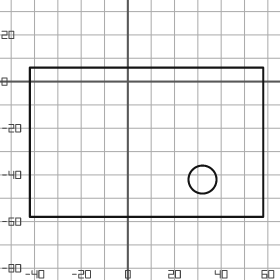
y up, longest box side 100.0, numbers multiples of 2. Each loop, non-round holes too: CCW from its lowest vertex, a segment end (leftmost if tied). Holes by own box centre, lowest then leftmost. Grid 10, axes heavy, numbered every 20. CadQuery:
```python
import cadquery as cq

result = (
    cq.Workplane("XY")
    .moveTo(-42.0, -58.0)
    .lineTo(58.0, -58.0)
    .lineTo(58.0, 6.0)
    .lineTo(-42.0, 6.0)
    .close()
    .moveTo(32.0, -42.0)
    .circle(6.0)
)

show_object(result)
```